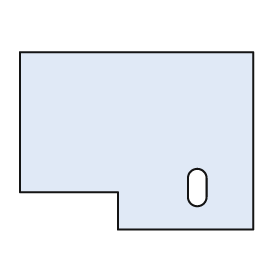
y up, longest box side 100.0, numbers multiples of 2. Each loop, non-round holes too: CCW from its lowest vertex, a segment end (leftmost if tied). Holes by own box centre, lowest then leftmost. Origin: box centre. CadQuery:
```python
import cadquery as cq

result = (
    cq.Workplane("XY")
    .moveTo(-8.0, -38.0)
    .lineTo(50.0, -38.0)
    .lineTo(50.0, 38.0)
    .lineTo(-50.0, 38.0)
    .lineTo(-50.0, -22.0)
    .lineTo(-8.0, -22.0)
    .close()
    .moveTo(22.0, -24.0)
    .threePointArc((26.0, -28.0), (30.0, -24.0))
    .lineTo(30.0, -16.0)
    .threePointArc((26.0, -12.0), (22.0, -16.0))
    .close()
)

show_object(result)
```